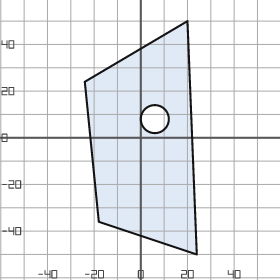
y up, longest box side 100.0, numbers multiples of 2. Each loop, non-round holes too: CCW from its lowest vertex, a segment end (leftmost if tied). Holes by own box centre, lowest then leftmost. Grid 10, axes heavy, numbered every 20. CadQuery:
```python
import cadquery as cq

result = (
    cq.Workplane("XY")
    .moveTo(24.0, -50.0)
    .lineTo(20.0, 50.0)
    .lineTo(-24.0, 24.0)
    .lineTo(-18.0, -36.0)
    .close()
    .moveTo(6.0, 8.0)
    .circle(6.0)
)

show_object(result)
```